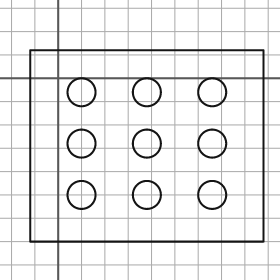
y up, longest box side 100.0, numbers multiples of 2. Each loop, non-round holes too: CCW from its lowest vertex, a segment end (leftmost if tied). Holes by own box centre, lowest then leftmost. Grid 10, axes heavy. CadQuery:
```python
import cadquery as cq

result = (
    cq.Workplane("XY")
    .moveTo(-12.0, -70.0)
    .lineTo(88.0, -70.0)
    .lineTo(88.0, 12.0)
    .lineTo(-12.0, 12.0)
    .close()
    .moveTo(10.0, -50.0)
    .circle(6.0)
    .moveTo(38.0, -50.0)
    .circle(6.0)
    .moveTo(66.0, -50.0)
    .circle(6.0)
    .moveTo(10.0, -28.0)
    .circle(6.0)
    .moveTo(38.0, -28.0)
    .circle(6.0)
    .moveTo(66.0, -28.0)
    .circle(6.0)
    .moveTo(10.0, -6.0)
    .circle(6.0)
    .moveTo(38.0, -6.0)
    .circle(6.0)
    .moveTo(66.0, -6.0)
    .circle(6.0)
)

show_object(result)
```